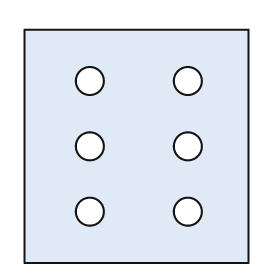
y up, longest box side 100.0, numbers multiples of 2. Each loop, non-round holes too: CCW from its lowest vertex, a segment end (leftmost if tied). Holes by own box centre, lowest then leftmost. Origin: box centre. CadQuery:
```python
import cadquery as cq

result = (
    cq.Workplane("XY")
    .moveTo(-48.0, -50.0)
    .lineTo(48.0, -50.0)
    .lineTo(48.0, 50.0)
    .lineTo(-48.0, 50.0)
    .close()
    .moveTo(-20.0, -28.0)
    .circle(6.0)
    .moveTo(22.0, -28.0)
    .circle(6.0)
    .moveTo(-20.0, 0.0)
    .circle(6.0)
    .moveTo(22.0, 0.0)
    .circle(6.0)
    .moveTo(-20.0, 28.0)
    .circle(6.0)
    .moveTo(22.0, 28.0)
    .circle(6.0)
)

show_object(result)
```